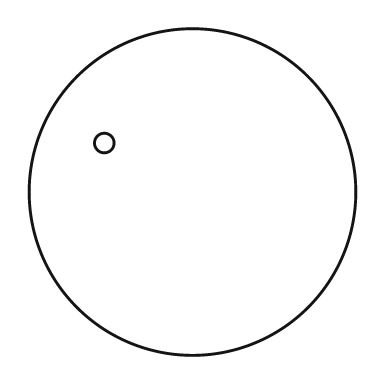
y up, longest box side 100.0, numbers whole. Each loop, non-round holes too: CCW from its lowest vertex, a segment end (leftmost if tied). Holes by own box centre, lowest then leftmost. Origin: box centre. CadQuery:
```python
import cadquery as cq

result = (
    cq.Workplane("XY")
    .moveTo(0.0, 0.0)
    .circle(50.0)
    .moveTo(-27.0, 15.0)
    .circle(3.0)
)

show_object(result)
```